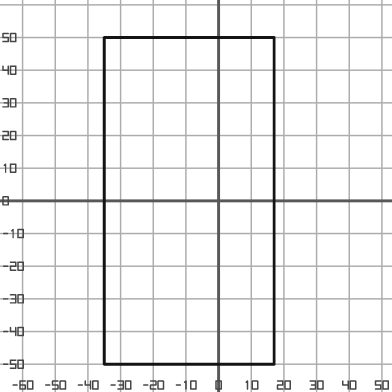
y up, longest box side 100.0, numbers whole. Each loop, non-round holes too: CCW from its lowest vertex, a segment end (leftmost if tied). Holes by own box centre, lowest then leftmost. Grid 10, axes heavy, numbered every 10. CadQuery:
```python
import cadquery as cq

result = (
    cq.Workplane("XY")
    .moveTo(-35.0, -50.0)
    .lineTo(17.0, -50.0)
    .lineTo(17.0, 50.0)
    .lineTo(-35.0, 50.0)
    .close()
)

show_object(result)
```